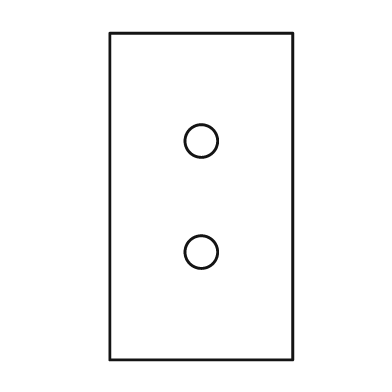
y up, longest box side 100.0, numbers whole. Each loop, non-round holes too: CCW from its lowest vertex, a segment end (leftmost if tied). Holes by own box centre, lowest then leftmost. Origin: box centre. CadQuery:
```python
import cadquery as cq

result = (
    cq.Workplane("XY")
    .moveTo(-28.0, -50.0)
    .lineTo(28.0, -50.0)
    .lineTo(28.0, 50.0)
    .lineTo(-28.0, 50.0)
    .close()
    .moveTo(0.0, -17.0)
    .circle(5.0)
    .moveTo(0.0, 17.0)
    .circle(5.0)
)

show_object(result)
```